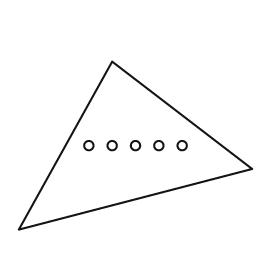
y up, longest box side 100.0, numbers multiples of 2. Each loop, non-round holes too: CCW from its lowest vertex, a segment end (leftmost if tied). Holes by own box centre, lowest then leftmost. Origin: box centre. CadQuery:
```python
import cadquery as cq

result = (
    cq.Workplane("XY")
    .moveTo(-50.0, -36.0)
    .lineTo(50.0, -10.0)
    .lineTo(-10.0, 36.0)
    .close()
    .moveTo(-20.0, 0.0)
    .circle(2.0)
    .moveTo(-10.0, 0.0)
    .circle(2.0)
    .moveTo(0.0, 0.0)
    .circle(2.0)
    .moveTo(10.0, 0.0)
    .circle(2.0)
    .moveTo(20.0, 0.0)
    .circle(2.0)
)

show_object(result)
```